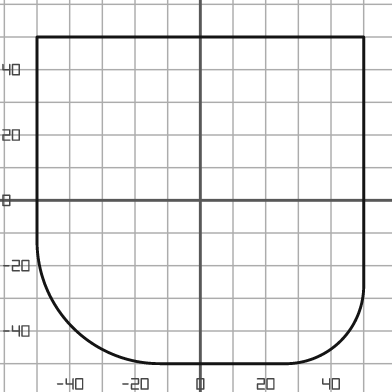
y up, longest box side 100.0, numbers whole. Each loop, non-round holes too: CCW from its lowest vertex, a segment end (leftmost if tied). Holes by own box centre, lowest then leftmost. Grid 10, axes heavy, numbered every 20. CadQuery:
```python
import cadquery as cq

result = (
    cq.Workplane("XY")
    .moveTo(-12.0, -50.0)
    .lineTo(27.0, -50.0)
    .threePointArc((43.0, -43.0), (50.0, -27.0))
    .lineTo(50.0, 50.0)
    .lineTo(-50.0, 50.0)
    .lineTo(-50.0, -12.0)
    .threePointArc((-39.0, -39.0), (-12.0, -50.0))
    .close()
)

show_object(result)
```